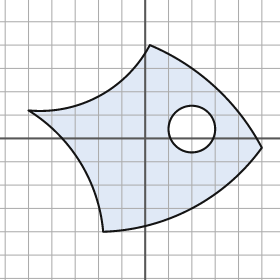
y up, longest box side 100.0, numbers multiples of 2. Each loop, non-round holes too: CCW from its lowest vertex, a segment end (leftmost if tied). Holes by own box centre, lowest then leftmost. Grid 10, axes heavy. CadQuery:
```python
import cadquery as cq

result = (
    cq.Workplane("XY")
    .moveTo(-18.0, -40.0)
    .threePointArc((20.0, -30.0), (50.0, -4.0))
    .threePointArc((30.0, 22.0), (2.0, 40.0))
    .threePointArc((-20.0, 18.0), (-50.0, 12.0))
    .threePointArc((-28.0, -10.0), (-18.0, -40.0))
    .close()
    .moveTo(20.0, 4.0)
    .circle(10.0)
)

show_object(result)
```